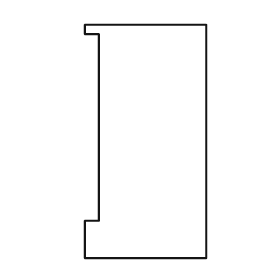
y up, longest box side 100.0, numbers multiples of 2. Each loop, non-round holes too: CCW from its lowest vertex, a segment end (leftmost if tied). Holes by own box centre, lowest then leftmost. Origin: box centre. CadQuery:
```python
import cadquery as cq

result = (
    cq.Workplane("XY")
    .moveTo(-26.0, -50.0)
    .lineTo(26.0, -50.0)
    .lineTo(26.0, 50.0)
    .lineTo(-26.0, 50.0)
    .lineTo(-26.0, 46.0)
    .lineTo(-20.0, 46.0)
    .lineTo(-20.0, -34.0)
    .lineTo(-26.0, -34.0)
    .close()
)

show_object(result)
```